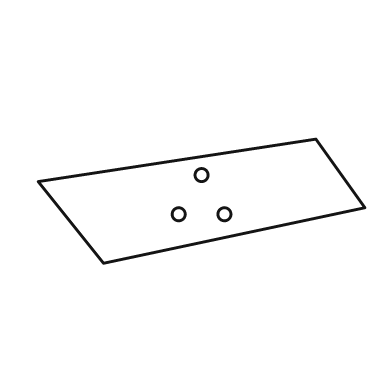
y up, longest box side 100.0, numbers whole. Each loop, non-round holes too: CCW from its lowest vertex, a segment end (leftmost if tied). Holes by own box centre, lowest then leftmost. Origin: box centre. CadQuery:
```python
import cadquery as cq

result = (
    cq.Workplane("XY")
    .moveTo(-30.0, -19.0)
    .lineTo(50.0, -2.0)
    .lineTo(35.0, 19.0)
    .lineTo(-50.0, 6.0)
    .close()
    .moveTo(-7.0, -4.0)
    .circle(2.0)
    .moveTo(7.0, -4.0)
    .circle(2.0)
    .moveTo(0.0, 8.0)
    .circle(2.0)
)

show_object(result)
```